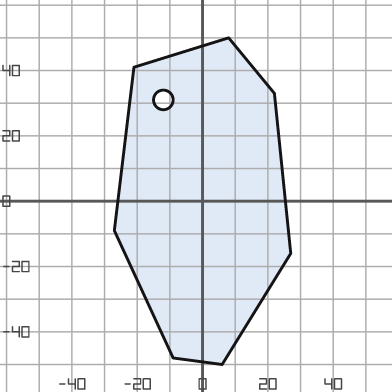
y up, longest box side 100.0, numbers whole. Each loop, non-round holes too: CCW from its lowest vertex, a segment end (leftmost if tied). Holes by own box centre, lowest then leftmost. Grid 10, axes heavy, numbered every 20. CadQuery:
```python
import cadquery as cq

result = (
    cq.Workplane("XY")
    .moveTo(6.0, -50.0)
    .lineTo(27.0, -16.0)
    .lineTo(22.0, 33.0)
    .lineTo(8.0, 50.0)
    .lineTo(-21.0, 41.0)
    .lineTo(-27.0, -9.0)
    .lineTo(-9.0, -48.0)
    .close()
    .moveTo(-12.0, 31.0)
    .circle(3.0)
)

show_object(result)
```